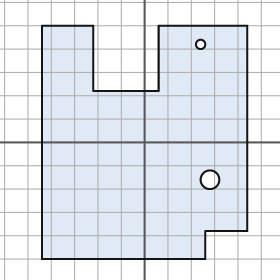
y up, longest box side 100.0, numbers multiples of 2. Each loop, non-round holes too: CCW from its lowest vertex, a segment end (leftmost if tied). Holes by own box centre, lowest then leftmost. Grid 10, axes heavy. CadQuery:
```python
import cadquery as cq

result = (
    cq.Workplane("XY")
    .moveTo(-44.0, -50.0)
    .lineTo(26.0, -50.0)
    .lineTo(26.0, -38.0)
    .lineTo(44.0, -38.0)
    .lineTo(44.0, 50.0)
    .lineTo(6.0, 50.0)
    .lineTo(6.0, 22.0)
    .lineTo(-22.0, 22.0)
    .lineTo(-22.0, 50.0)
    .lineTo(-44.0, 50.0)
    .close()
    .moveTo(28.0, -16.0)
    .circle(4.0)
    .moveTo(24.0, 42.0)
    .circle(2.0)
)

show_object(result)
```